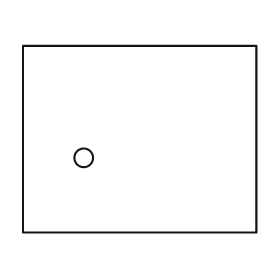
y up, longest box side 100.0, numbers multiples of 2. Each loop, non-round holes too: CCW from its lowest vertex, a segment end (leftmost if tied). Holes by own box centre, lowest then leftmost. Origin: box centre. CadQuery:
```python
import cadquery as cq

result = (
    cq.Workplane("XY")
    .moveTo(-50.0, -40.0)
    .lineTo(50.0, -40.0)
    .lineTo(50.0, 40.0)
    .lineTo(-50.0, 40.0)
    .close()
    .moveTo(-24.0, -8.0)
    .circle(4.0)
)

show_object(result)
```